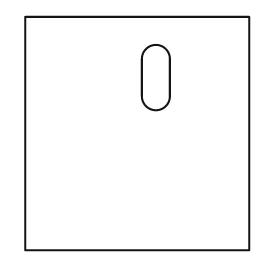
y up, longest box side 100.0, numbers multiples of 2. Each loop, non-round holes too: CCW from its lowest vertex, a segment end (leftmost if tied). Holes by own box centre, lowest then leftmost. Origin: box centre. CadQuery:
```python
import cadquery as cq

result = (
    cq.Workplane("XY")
    .moveTo(-48.0, -50.0)
    .lineTo(48.0, -50.0)
    .lineTo(48.0, 50.0)
    .lineTo(-48.0, 50.0)
    .close()
    .moveTo(2.0, 16.0)
    .threePointArc((8.0, 10.0), (14.0, 16.0))
    .lineTo(14.0, 32.0)
    .threePointArc((8.0, 38.0), (2.0, 32.0))
    .close()
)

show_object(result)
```